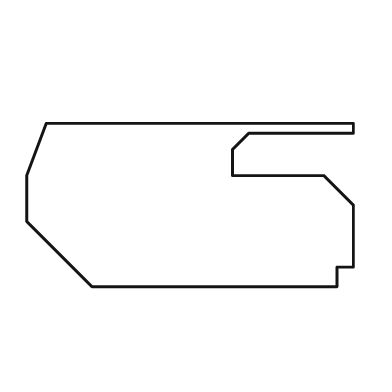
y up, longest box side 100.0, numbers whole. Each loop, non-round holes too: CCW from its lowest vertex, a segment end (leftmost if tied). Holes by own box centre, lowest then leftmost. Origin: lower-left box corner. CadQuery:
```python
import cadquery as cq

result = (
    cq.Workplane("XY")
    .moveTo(20.0, 0.0)
    .lineTo(95.0, 0.0)
    .lineTo(95.0, 6.0)
    .lineTo(100.0, 6.0)
    .lineTo(100.0, 25.0)
    .lineTo(91.0, 34.0)
    .lineTo(63.0, 34.0)
    .lineTo(63.0, 42.0)
    .lineTo(68.0, 47.0)
    .lineTo(100.0, 47.0)
    .lineTo(100.0, 50.0)
    .lineTo(6.0, 50.0)
    .lineTo(0.0, 34.0)
    .lineTo(0.0, 20.0)
    .close()
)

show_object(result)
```